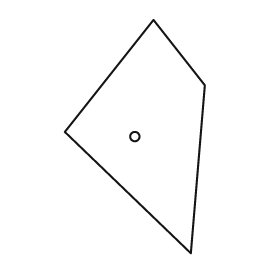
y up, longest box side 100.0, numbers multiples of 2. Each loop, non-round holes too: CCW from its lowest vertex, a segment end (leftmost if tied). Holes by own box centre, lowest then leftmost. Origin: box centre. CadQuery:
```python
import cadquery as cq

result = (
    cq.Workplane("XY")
    .moveTo(24.0, -50.0)
    .lineTo(30.0, 22.0)
    .lineTo(8.0, 50.0)
    .lineTo(-30.0, 2.0)
    .close()
    .moveTo(0.0, 0.0)
    .circle(2.0)
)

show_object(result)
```